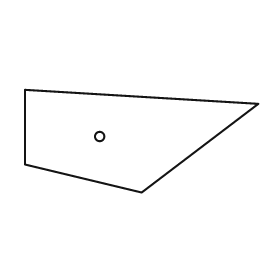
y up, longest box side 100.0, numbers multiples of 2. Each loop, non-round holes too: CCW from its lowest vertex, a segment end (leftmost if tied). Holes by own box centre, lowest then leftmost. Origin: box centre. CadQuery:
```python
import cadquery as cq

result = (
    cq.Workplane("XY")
    .moveTo(0.0, -22.0)
    .lineTo(50.0, 16.0)
    .lineTo(-50.0, 22.0)
    .lineTo(-50.0, -10.0)
    .close()
    .moveTo(-18.0, 2.0)
    .circle(2.0)
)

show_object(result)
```